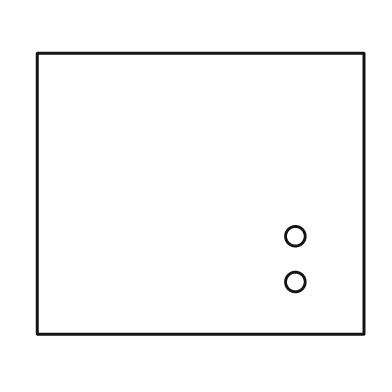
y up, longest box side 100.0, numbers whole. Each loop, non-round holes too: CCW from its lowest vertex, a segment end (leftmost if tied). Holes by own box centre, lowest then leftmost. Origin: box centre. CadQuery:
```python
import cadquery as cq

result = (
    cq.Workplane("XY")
    .moveTo(-50.0, -43.0)
    .lineTo(50.0, -43.0)
    .lineTo(50.0, 43.0)
    .lineTo(-50.0, 43.0)
    .close()
    .moveTo(29.0, -27.0)
    .circle(3.0)
    .moveTo(29.0, -13.0)
    .circle(3.0)
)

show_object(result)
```